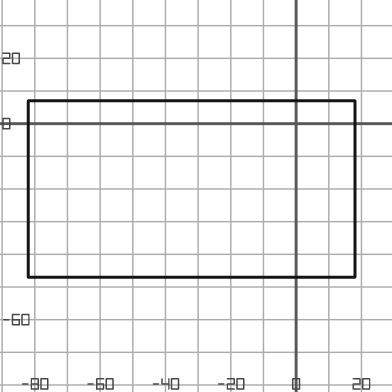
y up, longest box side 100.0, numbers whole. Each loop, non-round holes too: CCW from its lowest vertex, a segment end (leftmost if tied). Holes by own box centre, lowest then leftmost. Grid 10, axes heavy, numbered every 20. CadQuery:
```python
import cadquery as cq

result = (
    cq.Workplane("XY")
    .moveTo(-82.0, -47.0)
    .lineTo(18.0, -47.0)
    .lineTo(18.0, 7.0)
    .lineTo(-82.0, 7.0)
    .close()
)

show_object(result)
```